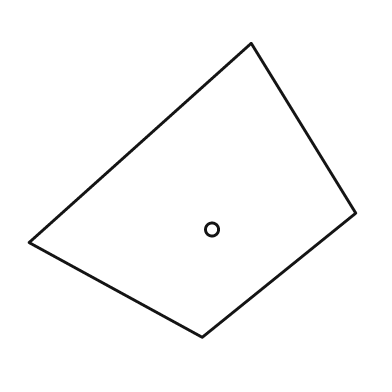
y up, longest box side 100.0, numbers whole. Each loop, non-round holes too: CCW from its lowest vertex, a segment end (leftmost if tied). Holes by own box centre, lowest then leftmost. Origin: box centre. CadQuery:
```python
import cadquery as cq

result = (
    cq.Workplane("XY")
    .moveTo(3.0, -45.0)
    .lineTo(50.0, -7.0)
    .lineTo(18.0, 45.0)
    .lineTo(-50.0, -16.0)
    .close()
    .moveTo(6.0, -12.0)
    .circle(2.0)
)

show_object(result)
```